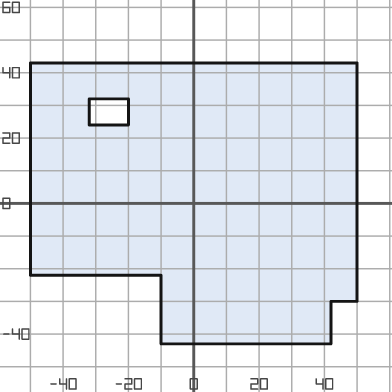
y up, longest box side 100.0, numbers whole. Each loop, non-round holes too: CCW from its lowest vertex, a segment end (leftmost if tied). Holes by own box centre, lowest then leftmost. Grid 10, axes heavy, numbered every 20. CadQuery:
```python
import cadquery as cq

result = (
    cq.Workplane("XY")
    .moveTo(-10.0, -43.0)
    .lineTo(42.0, -43.0)
    .lineTo(42.0, -30.0)
    .lineTo(50.0, -30.0)
    .lineTo(50.0, 43.0)
    .lineTo(-50.0, 43.0)
    .lineTo(-50.0, -22.0)
    .lineTo(-10.0, -22.0)
    .close()
    .moveTo(-32.0, 24.0)
    .lineTo(-20.0, 24.0)
    .lineTo(-20.0, 32.0)
    .lineTo(-32.0, 32.0)
    .close()
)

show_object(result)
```